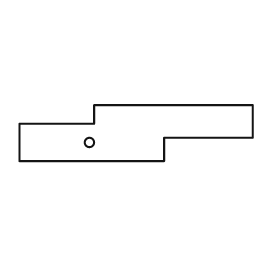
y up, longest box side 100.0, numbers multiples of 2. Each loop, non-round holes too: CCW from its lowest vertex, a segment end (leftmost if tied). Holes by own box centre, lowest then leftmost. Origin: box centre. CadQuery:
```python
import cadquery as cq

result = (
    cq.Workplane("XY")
    .moveTo(-50.0, -12.0)
    .lineTo(12.0, -12.0)
    .lineTo(12.0, -2.0)
    .lineTo(50.0, -2.0)
    .lineTo(50.0, 12.0)
    .lineTo(-18.0, 12.0)
    .lineTo(-18.0, 4.0)
    .lineTo(-50.0, 4.0)
    .close()
    .moveTo(-20.0, -4.0)
    .circle(2.0)
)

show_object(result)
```